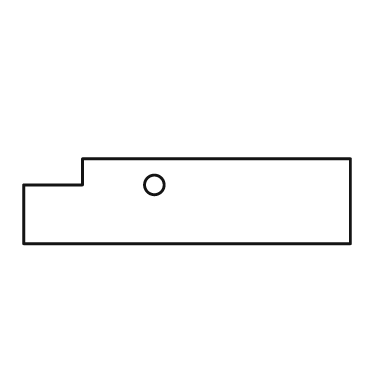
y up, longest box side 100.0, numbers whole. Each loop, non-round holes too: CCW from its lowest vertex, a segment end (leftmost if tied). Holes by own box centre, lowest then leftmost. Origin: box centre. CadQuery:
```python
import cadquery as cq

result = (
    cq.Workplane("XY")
    .moveTo(-50.0, -13.0)
    .lineTo(50.0, -13.0)
    .lineTo(50.0, 13.0)
    .lineTo(-32.0, 13.0)
    .lineTo(-32.0, 5.0)
    .lineTo(-50.0, 5.0)
    .close()
    .moveTo(-10.0, 5.0)
    .circle(3.0)
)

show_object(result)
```